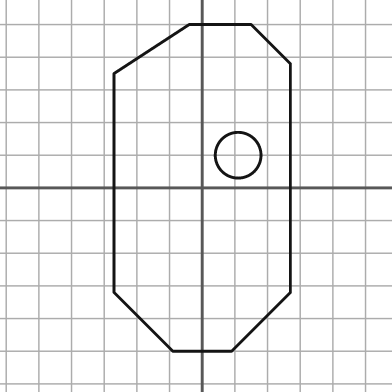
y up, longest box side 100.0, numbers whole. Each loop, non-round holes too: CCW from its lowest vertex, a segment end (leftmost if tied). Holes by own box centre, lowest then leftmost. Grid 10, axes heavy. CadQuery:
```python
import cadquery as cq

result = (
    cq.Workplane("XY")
    .moveTo(-9.0, -50.0)
    .lineTo(9.0, -50.0)
    .lineTo(27.0, -32.0)
    .lineTo(27.0, 38.0)
    .lineTo(15.0, 50.0)
    .lineTo(-4.0, 50.0)
    .lineTo(-27.0, 35.0)
    .lineTo(-27.0, -32.0)
    .close()
    .moveTo(11.0, 10.0)
    .circle(7.0)
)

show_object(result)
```